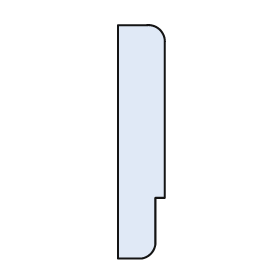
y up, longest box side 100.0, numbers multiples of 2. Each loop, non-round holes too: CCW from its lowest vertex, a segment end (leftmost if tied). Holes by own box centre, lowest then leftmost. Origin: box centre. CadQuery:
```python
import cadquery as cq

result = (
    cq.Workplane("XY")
    .moveTo(-10.0, -50.0)
    .lineTo(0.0, -50.0)
    .threePointArc((4.0, -48.0), (6.0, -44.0))
    .lineTo(6.0, -24.0)
    .lineTo(10.0, -24.0)
    .lineTo(10.0, 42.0)
    .threePointArc((8.0, 48.0), (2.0, 50.0))
    .lineTo(-10.0, 50.0)
    .close()
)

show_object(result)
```